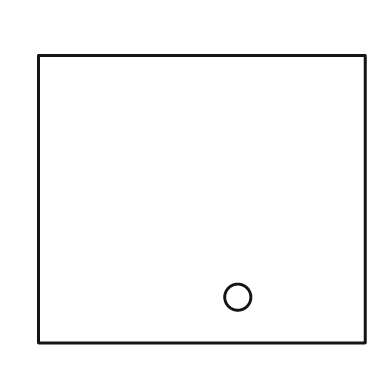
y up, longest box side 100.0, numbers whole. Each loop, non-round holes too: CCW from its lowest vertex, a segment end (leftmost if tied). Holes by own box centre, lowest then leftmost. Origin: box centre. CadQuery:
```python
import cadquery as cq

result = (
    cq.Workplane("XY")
    .moveTo(-50.0, -44.0)
    .lineTo(50.0, -44.0)
    .lineTo(50.0, 44.0)
    .lineTo(-50.0, 44.0)
    .close()
    .moveTo(11.0, -30.0)
    .circle(4.0)
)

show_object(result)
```